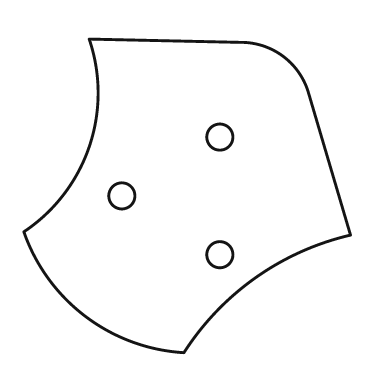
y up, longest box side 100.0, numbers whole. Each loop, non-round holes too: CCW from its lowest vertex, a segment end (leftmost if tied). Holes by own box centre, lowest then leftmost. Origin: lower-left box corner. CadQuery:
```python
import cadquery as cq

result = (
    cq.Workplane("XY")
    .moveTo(49.0, 0.0)
    .threePointArc((71.0, 23.0), (100.0, 36.0))
    .lineTo(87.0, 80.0)
    .threePointArc((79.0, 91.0), (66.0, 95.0))
    .lineTo(20.0, 96.0)
    .threePointArc((20.0, 63.0), (0.0, 37.0))
    .threePointArc((19.0, 11.0), (49.0, 0.0))
    .close()
    .moveTo(60.0, 30.0)
    .circle(4.0)
    .moveTo(30.0, 48.0)
    .circle(4.0)
    .moveTo(60.0, 66.0)
    .circle(4.0)
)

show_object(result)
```